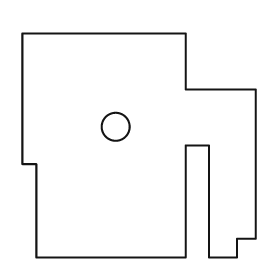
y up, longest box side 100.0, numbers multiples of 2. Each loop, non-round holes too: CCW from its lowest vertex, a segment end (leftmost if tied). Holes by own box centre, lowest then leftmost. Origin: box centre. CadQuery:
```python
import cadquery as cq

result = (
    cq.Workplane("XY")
    .moveTo(-44.0, -48.0)
    .lineTo(20.0, -48.0)
    .lineTo(20.0, 0.0)
    .lineTo(30.0, 0.0)
    .lineTo(30.0, -48.0)
    .lineTo(42.0, -48.0)
    .lineTo(42.0, -40.0)
    .lineTo(50.0, -40.0)
    .lineTo(50.0, 24.0)
    .lineTo(20.0, 24.0)
    .lineTo(20.0, 48.0)
    .lineTo(-50.0, 48.0)
    .lineTo(-50.0, -8.0)
    .lineTo(-44.0, -8.0)
    .close()
    .moveTo(-10.0, 8.0)
    .circle(6.0)
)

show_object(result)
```